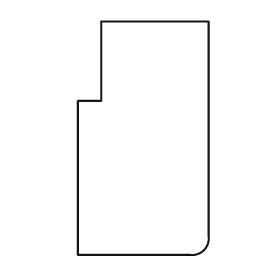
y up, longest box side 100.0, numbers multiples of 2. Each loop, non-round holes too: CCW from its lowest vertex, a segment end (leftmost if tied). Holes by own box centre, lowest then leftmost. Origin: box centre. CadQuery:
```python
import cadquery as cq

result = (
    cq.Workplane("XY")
    .moveTo(-28.0, -50.0)
    .lineTo(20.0, -50.0)
    .threePointArc((26.0, -48.0), (28.0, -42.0))
    .lineTo(28.0, 50.0)
    .lineTo(-18.0, 50.0)
    .lineTo(-18.0, 16.0)
    .lineTo(-28.0, 16.0)
    .close()
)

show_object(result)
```